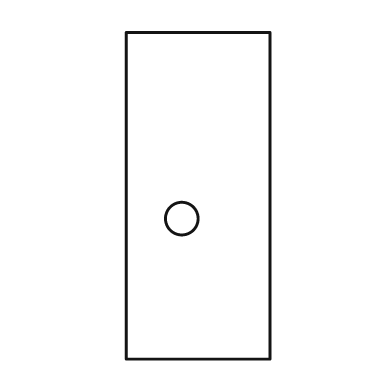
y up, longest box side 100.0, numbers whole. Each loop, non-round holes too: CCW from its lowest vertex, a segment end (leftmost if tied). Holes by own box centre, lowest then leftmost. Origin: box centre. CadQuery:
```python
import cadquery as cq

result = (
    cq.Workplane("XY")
    .moveTo(-22.0, -50.0)
    .lineTo(22.0, -50.0)
    .lineTo(22.0, 50.0)
    .lineTo(-22.0, 50.0)
    .close()
    .moveTo(-5.0, -7.0)
    .circle(5.0)
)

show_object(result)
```